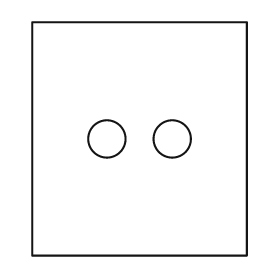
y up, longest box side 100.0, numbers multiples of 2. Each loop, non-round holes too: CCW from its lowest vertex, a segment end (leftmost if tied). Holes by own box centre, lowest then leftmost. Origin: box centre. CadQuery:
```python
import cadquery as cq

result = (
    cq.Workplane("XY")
    .moveTo(-46.0, -50.0)
    .lineTo(46.0, -50.0)
    .lineTo(46.0, 50.0)
    .lineTo(-46.0, 50.0)
    .close()
    .moveTo(-14.0, 0.0)
    .circle(8.0)
    .moveTo(14.0, 0.0)
    .circle(8.0)
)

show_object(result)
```